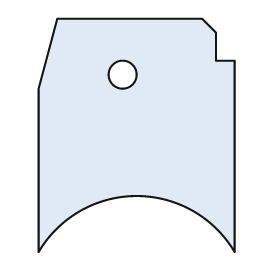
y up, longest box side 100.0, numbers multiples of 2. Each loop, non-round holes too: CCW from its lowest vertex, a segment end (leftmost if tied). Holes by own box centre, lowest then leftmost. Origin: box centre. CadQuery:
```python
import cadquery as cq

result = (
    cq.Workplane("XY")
    .moveTo(-42.0, -50.0)
    .threePointArc((0.0, -26.0), (42.0, -50.0))
    .lineTo(42.0, 32.0)
    .lineTo(34.0, 32.0)
    .lineTo(34.0, 44.0)
    .lineTo(28.0, 50.0)
    .lineTo(-34.0, 50.0)
    .lineTo(-42.0, 20.0)
    .close()
    .moveTo(-6.0, 26.0)
    .circle(6.0)
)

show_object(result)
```